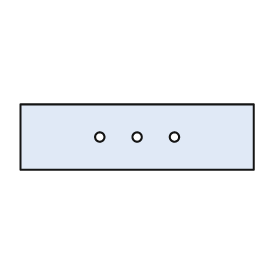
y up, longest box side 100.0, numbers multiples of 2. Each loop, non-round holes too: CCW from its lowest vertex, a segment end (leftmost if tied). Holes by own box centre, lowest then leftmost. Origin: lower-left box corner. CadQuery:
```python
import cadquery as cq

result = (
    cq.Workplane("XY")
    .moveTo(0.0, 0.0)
    .lineTo(100.0, 0.0)
    .lineTo(100.0, 28.0)
    .lineTo(0.0, 28.0)
    .close()
    .moveTo(34.0, 14.0)
    .circle(2.0)
    .moveTo(50.0, 14.0)
    .circle(2.0)
    .moveTo(66.0, 14.0)
    .circle(2.0)
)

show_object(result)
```